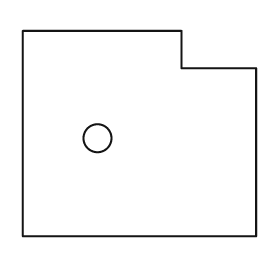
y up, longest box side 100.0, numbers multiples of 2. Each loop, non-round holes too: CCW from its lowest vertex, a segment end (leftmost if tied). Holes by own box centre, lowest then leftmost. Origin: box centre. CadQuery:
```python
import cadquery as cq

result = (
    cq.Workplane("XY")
    .moveTo(-50.0, -44.0)
    .lineTo(50.0, -44.0)
    .lineTo(50.0, 28.0)
    .lineTo(18.0, 28.0)
    .lineTo(18.0, 44.0)
    .lineTo(-50.0, 44.0)
    .close()
    .moveTo(-18.0, -2.0)
    .circle(6.0)
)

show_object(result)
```